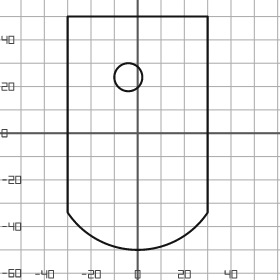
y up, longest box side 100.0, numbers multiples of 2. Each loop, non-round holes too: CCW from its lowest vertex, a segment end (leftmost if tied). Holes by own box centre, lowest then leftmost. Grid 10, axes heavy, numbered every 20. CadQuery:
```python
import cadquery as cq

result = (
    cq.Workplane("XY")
    .moveTo(-30.0, -34.0)
    .threePointArc((0.0, -50.0), (30.0, -34.0))
    .lineTo(30.0, 50.0)
    .lineTo(-30.0, 50.0)
    .close()
    .moveTo(-4.0, 24.0)
    .circle(6.0)
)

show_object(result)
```